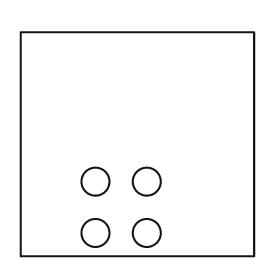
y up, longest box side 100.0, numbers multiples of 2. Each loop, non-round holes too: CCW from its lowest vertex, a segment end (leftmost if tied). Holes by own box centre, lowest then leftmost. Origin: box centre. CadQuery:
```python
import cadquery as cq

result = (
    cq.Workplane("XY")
    .moveTo(-50.0, -48.0)
    .lineTo(50.0, -48.0)
    .lineTo(50.0, 48.0)
    .lineTo(-50.0, 48.0)
    .close()
    .moveTo(-18.0, -38.0)
    .circle(6.0)
    .moveTo(4.0, -38.0)
    .circle(6.0)
    .moveTo(-18.0, -16.0)
    .circle(6.0)
    .moveTo(4.0, -16.0)
    .circle(6.0)
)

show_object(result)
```